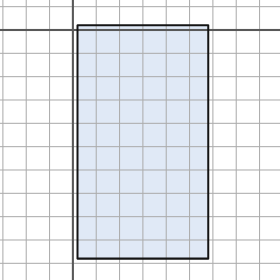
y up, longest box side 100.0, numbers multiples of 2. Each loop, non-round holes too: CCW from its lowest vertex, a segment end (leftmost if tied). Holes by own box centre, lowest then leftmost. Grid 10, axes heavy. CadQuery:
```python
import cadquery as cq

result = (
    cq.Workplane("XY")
    .moveTo(2.0, -98.0)
    .lineTo(58.0, -98.0)
    .lineTo(58.0, 2.0)
    .lineTo(2.0, 2.0)
    .close()
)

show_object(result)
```